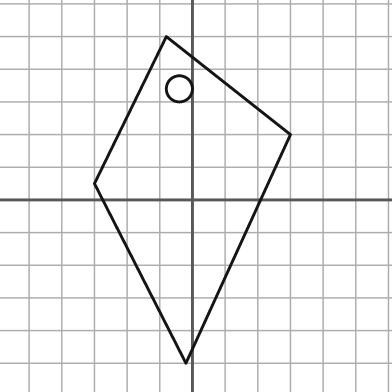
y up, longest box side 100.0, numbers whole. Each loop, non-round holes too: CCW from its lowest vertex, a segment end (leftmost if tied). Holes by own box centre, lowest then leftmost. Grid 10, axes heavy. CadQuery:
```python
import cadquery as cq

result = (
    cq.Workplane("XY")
    .moveTo(-2.0, -50.0)
    .lineTo(30.0, 20.0)
    .lineTo(-8.0, 50.0)
    .lineTo(-30.0, 5.0)
    .close()
    .moveTo(-4.0, 34.0)
    .circle(4.0)
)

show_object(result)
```